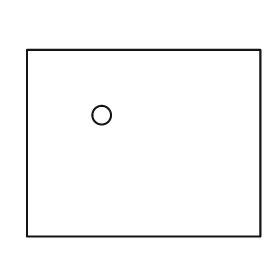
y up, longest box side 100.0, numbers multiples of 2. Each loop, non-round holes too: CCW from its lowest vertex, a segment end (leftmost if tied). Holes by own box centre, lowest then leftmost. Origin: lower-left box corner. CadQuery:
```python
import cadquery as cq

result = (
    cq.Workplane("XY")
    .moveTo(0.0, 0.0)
    .lineTo(100.0, 0.0)
    .lineTo(100.0, 80.0)
    .lineTo(0.0, 80.0)
    .close()
    .moveTo(32.0, 52.0)
    .circle(4.0)
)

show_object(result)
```